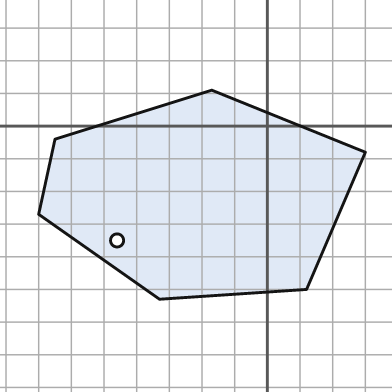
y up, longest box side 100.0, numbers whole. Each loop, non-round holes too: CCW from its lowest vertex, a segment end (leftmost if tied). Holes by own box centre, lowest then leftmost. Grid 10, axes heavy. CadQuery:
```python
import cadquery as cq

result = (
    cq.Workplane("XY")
    .moveTo(-33.0, -53.0)
    .lineTo(12.0, -50.0)
    .lineTo(30.0, -8.0)
    .lineTo(-17.0, 11.0)
    .lineTo(-65.0, -4.0)
    .lineTo(-70.0, -27.0)
    .close()
    .moveTo(-46.0, -35.0)
    .circle(2.0)
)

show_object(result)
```